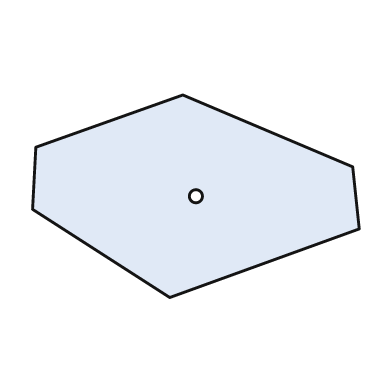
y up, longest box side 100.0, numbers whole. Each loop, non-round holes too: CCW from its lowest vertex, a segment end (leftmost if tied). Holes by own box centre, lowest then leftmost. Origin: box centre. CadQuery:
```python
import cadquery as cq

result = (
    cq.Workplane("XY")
    .moveTo(-8.0, -31.0)
    .lineTo(50.0, -10.0)
    .lineTo(48.0, 9.0)
    .lineTo(-4.0, 31.0)
    .lineTo(-49.0, 15.0)
    .lineTo(-50.0, -4.0)
    .close()
    .moveTo(0.0, 0.0)
    .circle(2.0)
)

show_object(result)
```